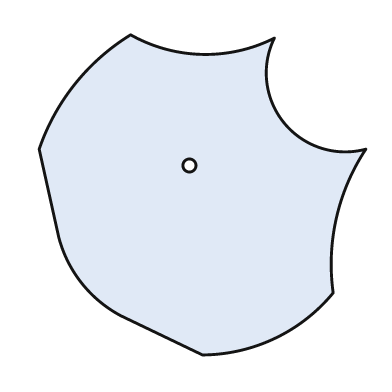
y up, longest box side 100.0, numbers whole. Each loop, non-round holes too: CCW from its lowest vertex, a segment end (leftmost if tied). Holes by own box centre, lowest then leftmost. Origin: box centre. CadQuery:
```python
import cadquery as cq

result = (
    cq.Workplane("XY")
    .moveTo(0.0, -49.0)
    .threePointArc((22.0, -44.0), (40.0, -30.0))
    .threePointArc((41.0, -7.0), (50.0, 14.0))
    .threePointArc((25.0, 22.0), (22.0, 48.0))
    .threePointArc((0.0, 43.0), (-22.0, 49.0))
    .threePointArc((-39.0, 34.0), (-50.0, 14.0))
    .lineTo(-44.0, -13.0)
    .threePointArc((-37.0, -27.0), (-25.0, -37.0))
    .close()
    .moveTo(-4.0, 9.0)
    .circle(2.0)
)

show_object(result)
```